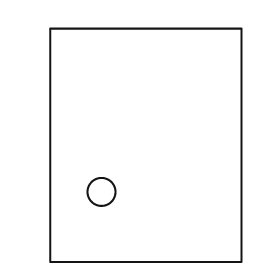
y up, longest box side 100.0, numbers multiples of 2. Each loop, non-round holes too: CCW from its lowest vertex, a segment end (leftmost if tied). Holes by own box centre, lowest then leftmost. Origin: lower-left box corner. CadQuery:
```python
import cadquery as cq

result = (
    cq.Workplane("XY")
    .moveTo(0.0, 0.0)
    .lineTo(82.0, 0.0)
    .lineTo(82.0, 100.0)
    .lineTo(0.0, 100.0)
    .close()
    .moveTo(22.0, 30.0)
    .circle(6.0)
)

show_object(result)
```